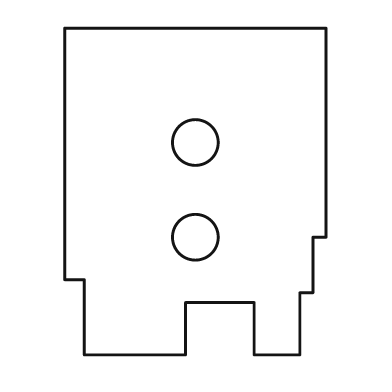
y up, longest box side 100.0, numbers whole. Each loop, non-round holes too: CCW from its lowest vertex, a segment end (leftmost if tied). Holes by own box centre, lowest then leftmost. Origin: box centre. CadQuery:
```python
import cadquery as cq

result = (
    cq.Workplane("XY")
    .moveTo(-34.0, -50.0)
    .lineTo(-3.0, -50.0)
    .lineTo(-3.0, -34.0)
    .lineTo(18.0, -34.0)
    .lineTo(18.0, -50.0)
    .lineTo(32.0, -50.0)
    .lineTo(32.0, -31.0)
    .lineTo(36.0, -31.0)
    .lineTo(36.0, -14.0)
    .lineTo(40.0, -14.0)
    .lineTo(40.0, 50.0)
    .lineTo(-40.0, 50.0)
    .lineTo(-40.0, -27.0)
    .lineTo(-34.0, -27.0)
    .close()
    .moveTo(0.0, -14.0)
    .circle(7.0)
    .moveTo(0.0, 15.0)
    .circle(7.0)
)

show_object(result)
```